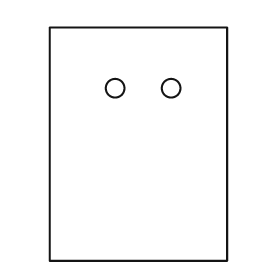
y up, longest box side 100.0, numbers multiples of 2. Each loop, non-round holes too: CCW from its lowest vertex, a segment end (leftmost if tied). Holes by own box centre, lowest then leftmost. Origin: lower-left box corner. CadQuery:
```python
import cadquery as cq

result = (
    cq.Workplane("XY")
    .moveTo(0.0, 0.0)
    .lineTo(76.0, 0.0)
    .lineTo(76.0, 100.0)
    .lineTo(0.0, 100.0)
    .close()
    .moveTo(28.0, 74.0)
    .circle(4.0)
    .moveTo(52.0, 74.0)
    .circle(4.0)
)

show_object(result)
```